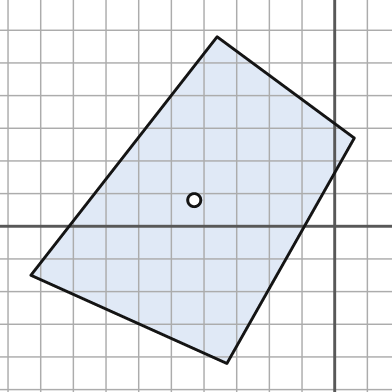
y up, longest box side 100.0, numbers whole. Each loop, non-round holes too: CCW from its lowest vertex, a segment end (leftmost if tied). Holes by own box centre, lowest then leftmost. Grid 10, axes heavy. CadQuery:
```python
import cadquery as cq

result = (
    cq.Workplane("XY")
    .moveTo(-33.0, -42.0)
    .lineTo(6.0, 27.0)
    .lineTo(-36.0, 58.0)
    .lineTo(-93.0, -15.0)
    .close()
    .moveTo(-43.0, 8.0)
    .circle(2.0)
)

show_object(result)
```